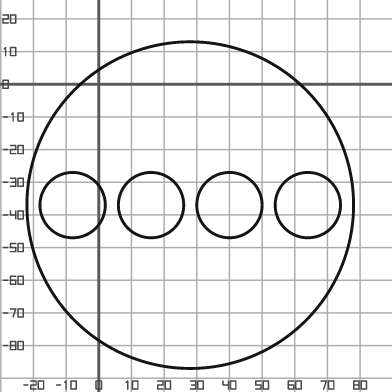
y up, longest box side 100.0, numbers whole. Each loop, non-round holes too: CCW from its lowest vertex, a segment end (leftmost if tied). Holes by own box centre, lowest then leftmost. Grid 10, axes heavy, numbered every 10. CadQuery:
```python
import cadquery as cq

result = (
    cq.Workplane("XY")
    .moveTo(28.0, -37.0)
    .circle(50.0)
    .moveTo(-8.0, -37.0)
    .circle(10.0)
    .moveTo(16.0, -37.0)
    .circle(10.0)
    .moveTo(40.0, -37.0)
    .circle(10.0)
    .moveTo(64.0, -37.0)
    .circle(10.0)
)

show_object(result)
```